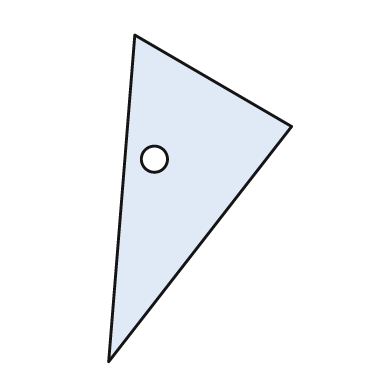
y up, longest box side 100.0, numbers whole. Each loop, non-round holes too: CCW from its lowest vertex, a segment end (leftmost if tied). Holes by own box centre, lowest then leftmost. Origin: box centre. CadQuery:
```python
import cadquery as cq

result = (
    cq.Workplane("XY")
    .moveTo(-28.0, -50.0)
    .lineTo(28.0, 22.0)
    .lineTo(-20.0, 50.0)
    .close()
    .moveTo(-14.0, 12.0)
    .circle(4.0)
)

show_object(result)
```